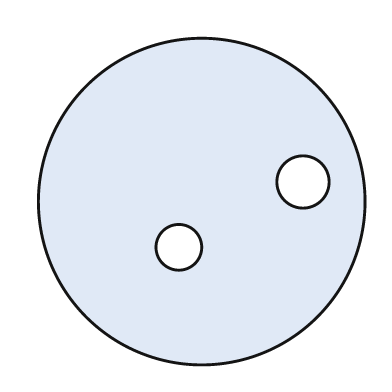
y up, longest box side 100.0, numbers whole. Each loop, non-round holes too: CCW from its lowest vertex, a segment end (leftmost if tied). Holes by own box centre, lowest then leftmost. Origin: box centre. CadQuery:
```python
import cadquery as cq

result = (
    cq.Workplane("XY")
    .moveTo(0.0, 0.0)
    .circle(50.0)
    .moveTo(-7.0, -14.0)
    .circle(7.0)
    .moveTo(31.0, 6.0)
    .circle(8.0)
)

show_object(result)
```